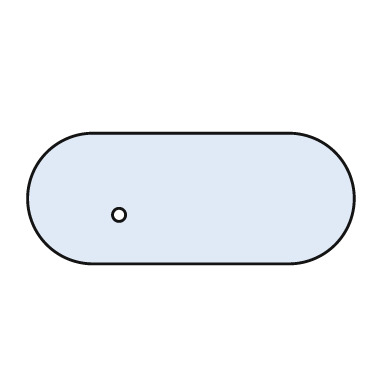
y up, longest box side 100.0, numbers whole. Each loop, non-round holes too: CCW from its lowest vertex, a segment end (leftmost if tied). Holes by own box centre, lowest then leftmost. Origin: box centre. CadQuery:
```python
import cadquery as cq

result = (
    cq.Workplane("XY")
    .moveTo(-30.0, -20.0)
    .lineTo(30.0, -20.0)
    .threePointArc((50.0, 0.0), (30.0, 20.0))
    .lineTo(-30.0, 20.0)
    .threePointArc((-50.0, 0.0), (-30.0, -20.0))
    .close()
    .moveTo(-22.0, -5.0)
    .circle(2.0)
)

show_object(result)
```